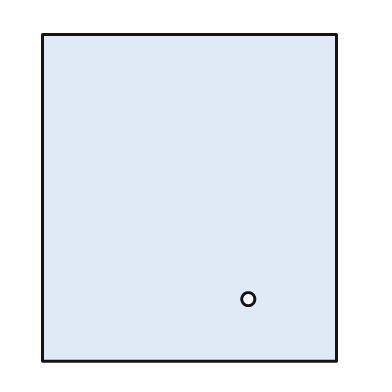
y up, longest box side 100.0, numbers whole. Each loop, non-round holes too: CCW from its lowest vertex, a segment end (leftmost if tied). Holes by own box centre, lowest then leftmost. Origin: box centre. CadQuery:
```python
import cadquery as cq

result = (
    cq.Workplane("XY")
    .moveTo(-45.0, -50.0)
    .lineTo(45.0, -50.0)
    .lineTo(45.0, 50.0)
    .lineTo(-45.0, 50.0)
    .close()
    .moveTo(18.0, -31.0)
    .circle(2.0)
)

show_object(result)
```